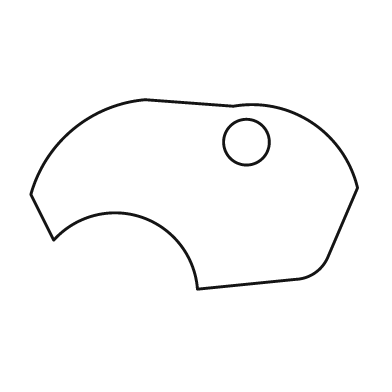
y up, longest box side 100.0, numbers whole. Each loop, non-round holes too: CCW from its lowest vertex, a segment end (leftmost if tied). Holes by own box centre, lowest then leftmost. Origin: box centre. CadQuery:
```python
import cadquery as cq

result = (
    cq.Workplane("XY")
    .moveTo(1.0, -29.0)
    .lineTo(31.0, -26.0)
    .threePointArc((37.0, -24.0), (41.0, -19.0))
    .lineTo(50.0, 2.0)
    .threePointArc((36.0, 22.0), (12.0, 27.0))
    .lineTo(-15.0, 29.0)
    .threePointArc((-37.0, 20.0), (-50.0, 0.0))
    .lineTo(-43.0, -14.0)
    .threePointArc((-16.0, -7.0), (1.0, -29.0))
    .close()
    .moveTo(16.0, 16.0)
    .circle(7.0)
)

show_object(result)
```